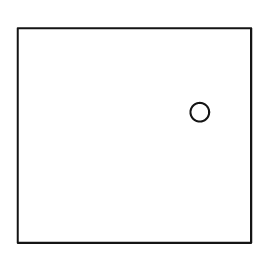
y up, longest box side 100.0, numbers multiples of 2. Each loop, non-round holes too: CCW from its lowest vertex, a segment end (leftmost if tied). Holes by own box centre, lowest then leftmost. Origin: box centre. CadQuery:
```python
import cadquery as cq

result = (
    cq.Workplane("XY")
    .moveTo(-50.0, -46.0)
    .lineTo(50.0, -46.0)
    .lineTo(50.0, 46.0)
    .lineTo(-50.0, 46.0)
    .close()
    .moveTo(28.0, 10.0)
    .circle(4.0)
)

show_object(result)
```